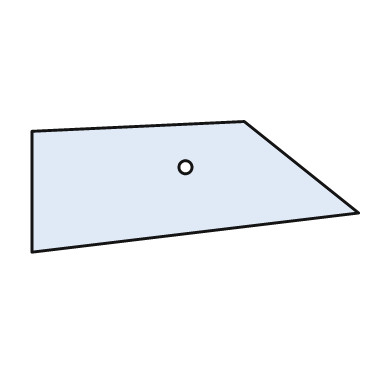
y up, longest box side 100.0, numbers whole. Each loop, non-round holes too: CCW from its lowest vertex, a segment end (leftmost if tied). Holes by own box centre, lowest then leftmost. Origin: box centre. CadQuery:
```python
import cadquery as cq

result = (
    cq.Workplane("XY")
    .moveTo(-50.0, -20.0)
    .lineTo(50.0, -8.0)
    .lineTo(15.0, 20.0)
    .lineTo(-50.0, 17.0)
    .close()
    .moveTo(-3.0, 6.0)
    .circle(2.0)
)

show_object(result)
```